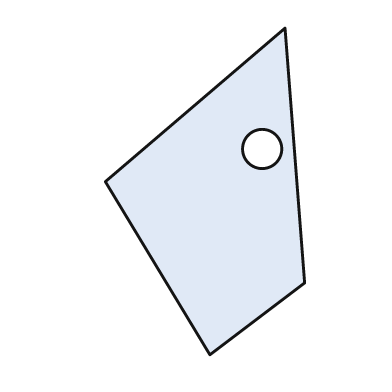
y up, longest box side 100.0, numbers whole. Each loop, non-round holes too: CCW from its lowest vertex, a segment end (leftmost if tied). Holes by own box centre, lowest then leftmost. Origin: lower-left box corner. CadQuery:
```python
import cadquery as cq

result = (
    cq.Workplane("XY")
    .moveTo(32.0, 0.0)
    .lineTo(61.0, 22.0)
    .lineTo(55.0, 100.0)
    .lineTo(0.0, 53.0)
    .close()
    .moveTo(48.0, 63.0)
    .circle(6.0)
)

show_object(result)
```